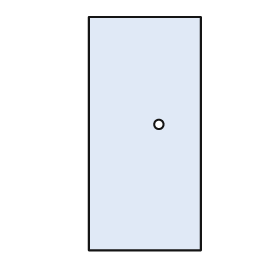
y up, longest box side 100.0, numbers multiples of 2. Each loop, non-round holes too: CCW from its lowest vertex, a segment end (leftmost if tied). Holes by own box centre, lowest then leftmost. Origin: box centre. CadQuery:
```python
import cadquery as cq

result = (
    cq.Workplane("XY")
    .moveTo(-24.0, -50.0)
    .lineTo(24.0, -50.0)
    .lineTo(24.0, 50.0)
    .lineTo(-24.0, 50.0)
    .close()
    .moveTo(6.0, 4.0)
    .circle(2.0)
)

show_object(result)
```